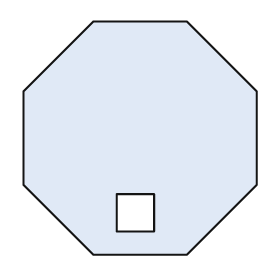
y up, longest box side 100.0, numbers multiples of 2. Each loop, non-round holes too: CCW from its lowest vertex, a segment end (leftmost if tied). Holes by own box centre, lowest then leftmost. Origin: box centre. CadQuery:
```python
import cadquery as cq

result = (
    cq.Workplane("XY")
    .moveTo(-20.0, -50.0)
    .lineTo(20.0, -50.0)
    .lineTo(50.0, -20.0)
    .lineTo(50.0, 20.0)
    .lineTo(20.0, 50.0)
    .lineTo(-20.0, 50.0)
    .lineTo(-50.0, 20.0)
    .lineTo(-50.0, -20.0)
    .close()
    .moveTo(-10.0, -40.0)
    .lineTo(6.0, -40.0)
    .lineTo(6.0, -24.0)
    .lineTo(-10.0, -24.0)
    .close()
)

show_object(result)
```